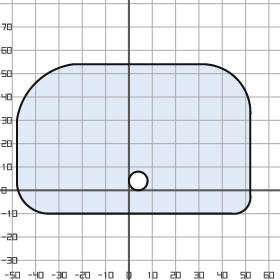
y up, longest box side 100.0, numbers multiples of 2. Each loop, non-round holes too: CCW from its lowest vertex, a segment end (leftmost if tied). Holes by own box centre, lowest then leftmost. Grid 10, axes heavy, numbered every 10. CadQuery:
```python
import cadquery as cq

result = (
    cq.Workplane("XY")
    .moveTo(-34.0, -10.0)
    .lineTo(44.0, -10.0)
    .threePointArc((50.0, -8.0), (52.0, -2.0))
    .lineTo(52.0, 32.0)
    .threePointArc((46.0, 48.0), (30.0, 54.0))
    .lineTo(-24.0, 54.0)
    .threePointArc((-40.0, 46.0), (-48.0, 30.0))
    .lineTo(-48.0, 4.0)
    .threePointArc((-44.0, -6.0), (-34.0, -10.0))
    .close()
    .moveTo(4.0, 4.0)
    .circle(4.0)
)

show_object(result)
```